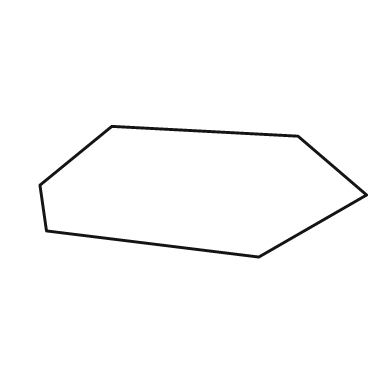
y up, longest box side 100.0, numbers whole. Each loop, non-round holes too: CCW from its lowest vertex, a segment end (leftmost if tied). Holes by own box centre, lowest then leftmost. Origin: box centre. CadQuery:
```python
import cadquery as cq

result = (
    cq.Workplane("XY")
    .moveTo(17.0, -20.0)
    .lineTo(50.0, -1.0)
    .lineTo(29.0, 17.0)
    .lineTo(-28.0, 20.0)
    .lineTo(-50.0, 2.0)
    .lineTo(-48.0, -12.0)
    .close()
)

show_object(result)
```